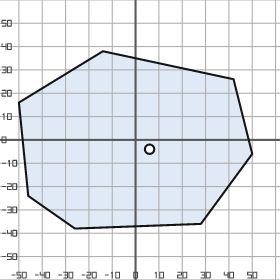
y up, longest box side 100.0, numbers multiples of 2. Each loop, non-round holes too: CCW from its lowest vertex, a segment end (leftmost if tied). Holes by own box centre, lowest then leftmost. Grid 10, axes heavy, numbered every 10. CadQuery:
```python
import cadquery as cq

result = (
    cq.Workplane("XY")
    .moveTo(-26.0, -38.0)
    .lineTo(28.0, -36.0)
    .lineTo(50.0, -6.0)
    .lineTo(42.0, 26.0)
    .lineTo(-14.0, 38.0)
    .lineTo(-50.0, 16.0)
    .lineTo(-46.0, -24.0)
    .close()
    .moveTo(6.0, -4.0)
    .circle(2.0)
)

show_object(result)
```